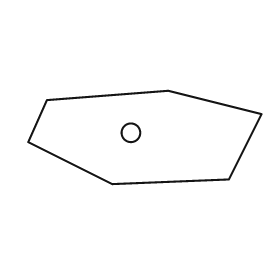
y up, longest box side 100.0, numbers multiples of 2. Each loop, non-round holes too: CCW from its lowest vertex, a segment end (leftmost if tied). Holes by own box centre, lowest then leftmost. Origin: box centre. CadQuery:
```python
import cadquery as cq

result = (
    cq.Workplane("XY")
    .moveTo(-14.0, -20.0)
    .lineTo(36.0, -18.0)
    .lineTo(50.0, 10.0)
    .lineTo(10.0, 20.0)
    .lineTo(-42.0, 16.0)
    .lineTo(-50.0, -2.0)
    .close()
    .moveTo(-6.0, 2.0)
    .circle(4.0)
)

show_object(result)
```